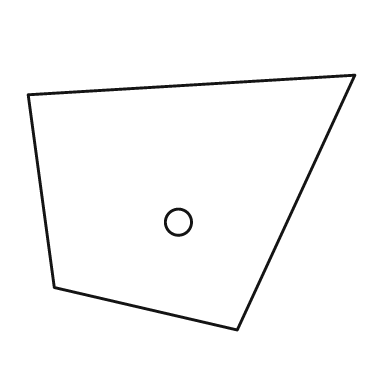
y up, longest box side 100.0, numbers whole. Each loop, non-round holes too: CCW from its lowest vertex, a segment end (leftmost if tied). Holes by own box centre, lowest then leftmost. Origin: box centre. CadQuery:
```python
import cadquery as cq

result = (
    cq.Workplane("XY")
    .moveTo(14.0, -39.0)
    .lineTo(50.0, 39.0)
    .lineTo(-50.0, 33.0)
    .lineTo(-42.0, -26.0)
    .close()
    .moveTo(-4.0, -6.0)
    .circle(4.0)
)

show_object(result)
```